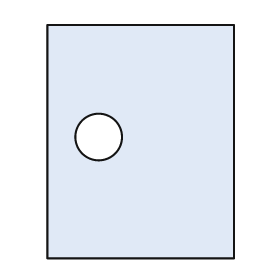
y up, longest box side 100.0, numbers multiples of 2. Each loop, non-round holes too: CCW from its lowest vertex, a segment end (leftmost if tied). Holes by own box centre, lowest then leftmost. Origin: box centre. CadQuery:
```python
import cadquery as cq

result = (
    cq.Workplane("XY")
    .moveTo(-40.0, -50.0)
    .lineTo(40.0, -50.0)
    .lineTo(40.0, 50.0)
    .lineTo(-40.0, 50.0)
    .close()
    .moveTo(-18.0, 2.0)
    .circle(10.0)
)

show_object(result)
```